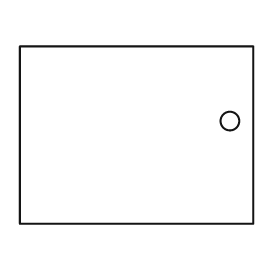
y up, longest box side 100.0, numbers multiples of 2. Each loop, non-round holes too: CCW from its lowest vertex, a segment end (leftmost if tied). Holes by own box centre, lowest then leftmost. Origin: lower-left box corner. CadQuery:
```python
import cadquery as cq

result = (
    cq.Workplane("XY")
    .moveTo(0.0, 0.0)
    .lineTo(100.0, 0.0)
    .lineTo(100.0, 76.0)
    .lineTo(0.0, 76.0)
    .close()
    .moveTo(90.0, 44.0)
    .circle(4.0)
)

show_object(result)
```